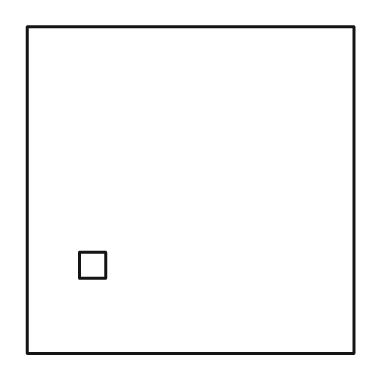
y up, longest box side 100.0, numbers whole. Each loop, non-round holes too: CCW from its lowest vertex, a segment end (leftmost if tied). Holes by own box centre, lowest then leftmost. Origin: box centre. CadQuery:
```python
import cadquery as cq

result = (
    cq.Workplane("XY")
    .moveTo(-50.0, -50.0)
    .lineTo(50.0, -50.0)
    .lineTo(50.0, 50.0)
    .lineTo(-50.0, 50.0)
    .close()
    .moveTo(-34.0, -27.0)
    .lineTo(-26.0, -27.0)
    .lineTo(-26.0, -19.0)
    .lineTo(-34.0, -19.0)
    .close()
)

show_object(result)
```